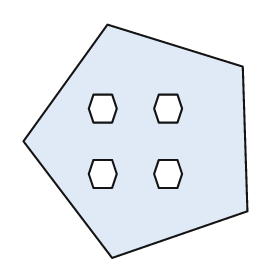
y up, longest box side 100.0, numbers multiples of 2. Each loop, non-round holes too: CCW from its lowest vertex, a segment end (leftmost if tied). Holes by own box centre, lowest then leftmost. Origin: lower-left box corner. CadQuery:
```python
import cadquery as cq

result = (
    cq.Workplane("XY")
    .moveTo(38.0, 0.0)
    .lineTo(96.0, 20.0)
    .lineTo(94.0, 82.0)
    .lineTo(36.0, 100.0)
    .lineTo(0.0, 50.0)
    .close()
    .moveTo(30.0, 30.0)
    .lineTo(38.0, 30.0)
    .lineTo(40.0, 36.0)
    .lineTo(38.0, 42.0)
    .lineTo(30.0, 42.0)
    .lineTo(28.0, 36.0)
    .close()
    .moveTo(58.0, 30.0)
    .lineTo(66.0, 30.0)
    .lineTo(68.0, 36.0)
    .lineTo(66.0, 42.0)
    .lineTo(58.0, 42.0)
    .lineTo(56.0, 36.0)
    .close()
    .moveTo(30.0, 58.0)
    .lineTo(38.0, 58.0)
    .lineTo(40.0, 64.0)
    .lineTo(38.0, 70.0)
    .lineTo(30.0, 70.0)
    .lineTo(28.0, 64.0)
    .close()
    .moveTo(58.0, 58.0)
    .lineTo(66.0, 58.0)
    .lineTo(68.0, 64.0)
    .lineTo(66.0, 70.0)
    .lineTo(58.0, 70.0)
    .lineTo(56.0, 64.0)
    .close()
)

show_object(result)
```